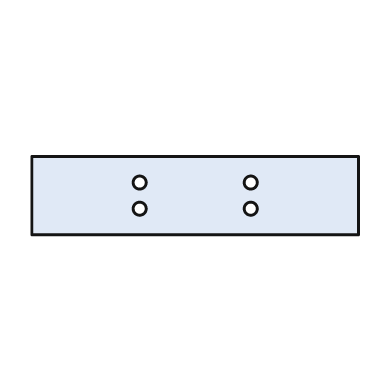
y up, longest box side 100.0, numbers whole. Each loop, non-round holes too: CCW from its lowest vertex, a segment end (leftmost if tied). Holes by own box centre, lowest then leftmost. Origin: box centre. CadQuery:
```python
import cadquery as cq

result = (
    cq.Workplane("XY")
    .moveTo(-50.0, -12.0)
    .lineTo(50.0, -12.0)
    .lineTo(50.0, 12.0)
    .lineTo(-50.0, 12.0)
    .close()
    .moveTo(-17.0, -4.0)
    .circle(2.0)
    .moveTo(17.0, -4.0)
    .circle(2.0)
    .moveTo(-17.0, 4.0)
    .circle(2.0)
    .moveTo(17.0, 4.0)
    .circle(2.0)
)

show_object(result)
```